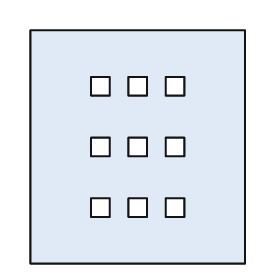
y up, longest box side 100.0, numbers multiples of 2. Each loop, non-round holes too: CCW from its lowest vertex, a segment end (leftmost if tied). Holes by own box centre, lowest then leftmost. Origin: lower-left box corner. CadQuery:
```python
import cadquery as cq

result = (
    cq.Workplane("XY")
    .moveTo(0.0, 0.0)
    .lineTo(92.0, 0.0)
    .lineTo(92.0, 100.0)
    .lineTo(0.0, 100.0)
    .close()
    .moveTo(26.0, 20.0)
    .lineTo(34.0, 20.0)
    .lineTo(34.0, 28.0)
    .lineTo(26.0, 28.0)
    .close()
    .moveTo(42.0, 20.0)
    .lineTo(50.0, 20.0)
    .lineTo(50.0, 28.0)
    .lineTo(42.0, 28.0)
    .close()
    .moveTo(58.0, 20.0)
    .lineTo(66.0, 20.0)
    .lineTo(66.0, 28.0)
    .lineTo(58.0, 28.0)
    .close()
    .moveTo(26.0, 46.0)
    .lineTo(34.0, 46.0)
    .lineTo(34.0, 54.0)
    .lineTo(26.0, 54.0)
    .close()
    .moveTo(42.0, 46.0)
    .lineTo(50.0, 46.0)
    .lineTo(50.0, 54.0)
    .lineTo(42.0, 54.0)
    .close()
    .moveTo(58.0, 46.0)
    .lineTo(66.0, 46.0)
    .lineTo(66.0, 54.0)
    .lineTo(58.0, 54.0)
    .close()
    .moveTo(26.0, 72.0)
    .lineTo(34.0, 72.0)
    .lineTo(34.0, 80.0)
    .lineTo(26.0, 80.0)
    .close()
    .moveTo(42.0, 72.0)
    .lineTo(50.0, 72.0)
    .lineTo(50.0, 80.0)
    .lineTo(42.0, 80.0)
    .close()
    .moveTo(58.0, 72.0)
    .lineTo(66.0, 72.0)
    .lineTo(66.0, 80.0)
    .lineTo(58.0, 80.0)
    .close()
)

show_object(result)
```